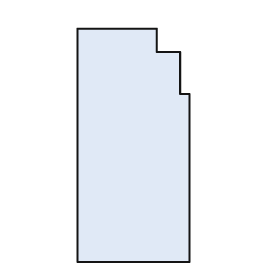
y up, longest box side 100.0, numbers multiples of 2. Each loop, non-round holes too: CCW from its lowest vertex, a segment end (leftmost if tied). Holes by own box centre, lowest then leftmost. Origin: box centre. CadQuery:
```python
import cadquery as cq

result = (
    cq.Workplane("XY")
    .moveTo(-24.0, -50.0)
    .lineTo(24.0, -50.0)
    .lineTo(24.0, 22.0)
    .lineTo(20.0, 22.0)
    .lineTo(20.0, 40.0)
    .lineTo(10.0, 40.0)
    .lineTo(10.0, 50.0)
    .lineTo(-24.0, 50.0)
    .close()
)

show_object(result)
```